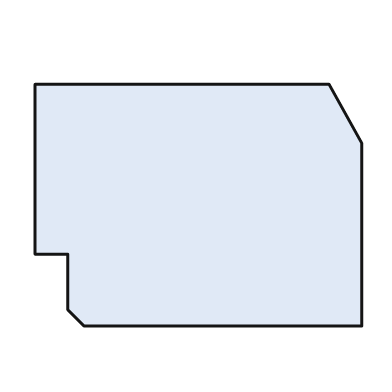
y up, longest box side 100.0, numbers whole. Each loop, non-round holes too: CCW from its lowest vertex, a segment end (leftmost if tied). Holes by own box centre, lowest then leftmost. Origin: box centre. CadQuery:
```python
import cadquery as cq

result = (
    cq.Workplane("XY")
    .moveTo(-35.0, -37.0)
    .lineTo(50.0, -37.0)
    .lineTo(50.0, 19.0)
    .lineTo(40.0, 37.0)
    .lineTo(-50.0, 37.0)
    .lineTo(-50.0, -15.0)
    .lineTo(-40.0, -15.0)
    .lineTo(-40.0, -32.0)
    .close()
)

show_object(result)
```